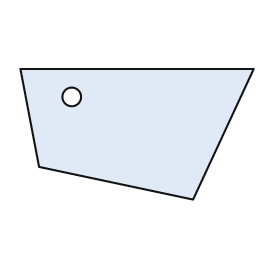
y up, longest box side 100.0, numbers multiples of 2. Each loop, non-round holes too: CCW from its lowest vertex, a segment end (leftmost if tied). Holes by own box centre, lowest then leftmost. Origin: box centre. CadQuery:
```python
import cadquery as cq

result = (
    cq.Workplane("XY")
    .moveTo(24.0, -28.0)
    .lineTo(50.0, 28.0)
    .lineTo(-50.0, 28.0)
    .lineTo(-42.0, -14.0)
    .close()
    .moveTo(-28.0, 16.0)
    .circle(4.0)
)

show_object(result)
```